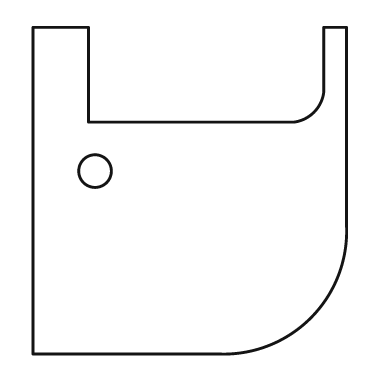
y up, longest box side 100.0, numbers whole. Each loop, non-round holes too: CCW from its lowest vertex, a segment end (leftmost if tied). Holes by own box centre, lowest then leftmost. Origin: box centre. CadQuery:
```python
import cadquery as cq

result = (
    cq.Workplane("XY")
    .moveTo(-48.0, -50.0)
    .lineTo(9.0, -50.0)
    .threePointArc((37.0, -39.0), (48.0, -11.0))
    .lineTo(48.0, 50.0)
    .lineTo(41.0, 50.0)
    .lineTo(41.0, 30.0)
    .threePointArc((38.0, 24.0), (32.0, 21.0))
    .lineTo(-31.0, 21.0)
    .lineTo(-31.0, 50.0)
    .lineTo(-48.0, 50.0)
    .close()
    .moveTo(-29.0, 6.0)
    .circle(5.0)
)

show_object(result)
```